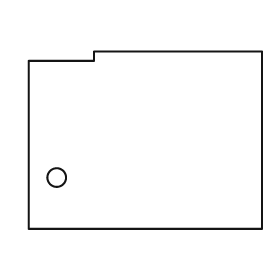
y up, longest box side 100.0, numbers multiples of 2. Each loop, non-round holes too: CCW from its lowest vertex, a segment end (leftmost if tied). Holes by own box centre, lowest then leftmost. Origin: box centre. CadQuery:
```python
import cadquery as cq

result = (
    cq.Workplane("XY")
    .moveTo(-50.0, -38.0)
    .lineTo(50.0, -38.0)
    .lineTo(50.0, 38.0)
    .lineTo(-22.0, 38.0)
    .lineTo(-22.0, 34.0)
    .lineTo(-50.0, 34.0)
    .close()
    .moveTo(-38.0, -16.0)
    .circle(4.0)
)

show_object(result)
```